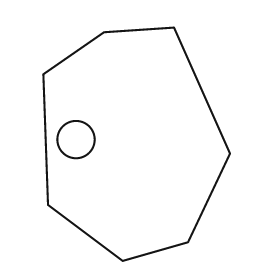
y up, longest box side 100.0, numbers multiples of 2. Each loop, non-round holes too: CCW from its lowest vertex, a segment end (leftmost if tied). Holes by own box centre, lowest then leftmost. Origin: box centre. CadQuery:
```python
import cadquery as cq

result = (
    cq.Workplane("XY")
    .moveTo(-6.0, -50.0)
    .lineTo(22.0, -42.0)
    .lineTo(40.0, -4.0)
    .lineTo(16.0, 50.0)
    .lineTo(-14.0, 48.0)
    .lineTo(-40.0, 30.0)
    .lineTo(-38.0, -26.0)
    .close()
    .moveTo(-26.0, 2.0)
    .circle(8.0)
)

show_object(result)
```